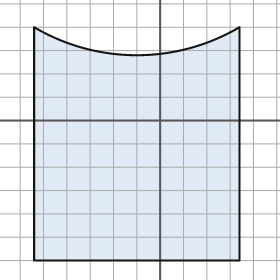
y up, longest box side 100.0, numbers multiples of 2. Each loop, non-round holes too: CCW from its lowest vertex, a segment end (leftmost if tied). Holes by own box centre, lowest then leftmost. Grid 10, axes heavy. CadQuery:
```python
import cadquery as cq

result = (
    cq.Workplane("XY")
    .moveTo(-54.0, -60.0)
    .lineTo(34.0, -60.0)
    .lineTo(34.0, 40.0)
    .threePointArc((-10.0, 28.0), (-54.0, 40.0))
    .close()
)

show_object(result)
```